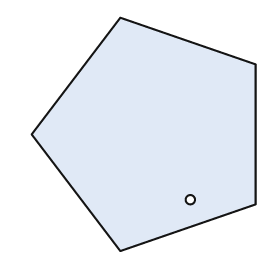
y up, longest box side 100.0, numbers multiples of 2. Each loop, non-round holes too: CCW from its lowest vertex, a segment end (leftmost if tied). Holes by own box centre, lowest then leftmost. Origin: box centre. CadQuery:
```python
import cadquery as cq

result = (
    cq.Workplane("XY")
    .moveTo(-10.0, -50.0)
    .lineTo(48.0, -30.0)
    .lineTo(48.0, 30.0)
    .lineTo(-10.0, 50.0)
    .lineTo(-48.0, 0.0)
    .close()
    .moveTo(20.0, -28.0)
    .circle(2.0)
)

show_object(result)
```